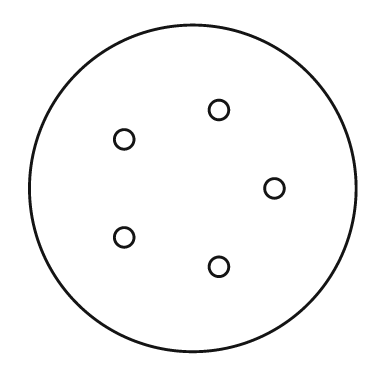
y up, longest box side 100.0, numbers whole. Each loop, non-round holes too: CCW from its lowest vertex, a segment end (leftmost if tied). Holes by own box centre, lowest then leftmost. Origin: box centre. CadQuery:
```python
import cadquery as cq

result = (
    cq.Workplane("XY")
    .moveTo(0.0, 0.0)
    .circle(50.0)
    .moveTo(8.0, -24.0)
    .circle(3.0)
    .moveTo(-21.0, -15.0)
    .circle(3.0)
    .moveTo(25.0, 0.0)
    .circle(3.0)
    .moveTo(-21.0, 15.0)
    .circle(3.0)
    .moveTo(8.0, 24.0)
    .circle(3.0)
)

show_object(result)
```